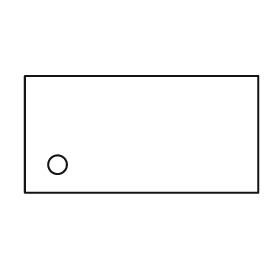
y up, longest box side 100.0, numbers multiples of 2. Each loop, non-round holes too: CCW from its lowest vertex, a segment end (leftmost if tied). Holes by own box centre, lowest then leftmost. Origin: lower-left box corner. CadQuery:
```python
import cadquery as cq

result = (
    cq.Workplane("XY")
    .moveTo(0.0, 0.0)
    .lineTo(100.0, 0.0)
    .lineTo(100.0, 50.0)
    .lineTo(0.0, 50.0)
    .close()
    .moveTo(14.0, 12.0)
    .circle(4.0)
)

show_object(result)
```